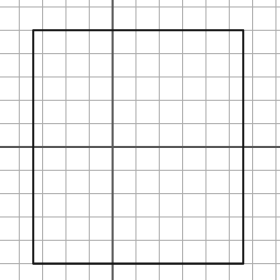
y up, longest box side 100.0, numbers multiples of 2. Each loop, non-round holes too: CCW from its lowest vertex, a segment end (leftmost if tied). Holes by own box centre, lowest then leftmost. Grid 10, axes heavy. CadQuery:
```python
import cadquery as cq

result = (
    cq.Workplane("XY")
    .moveTo(-34.0, -50.0)
    .lineTo(56.0, -50.0)
    .lineTo(56.0, 50.0)
    .lineTo(-34.0, 50.0)
    .close()
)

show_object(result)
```